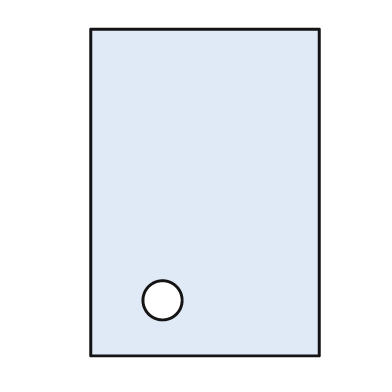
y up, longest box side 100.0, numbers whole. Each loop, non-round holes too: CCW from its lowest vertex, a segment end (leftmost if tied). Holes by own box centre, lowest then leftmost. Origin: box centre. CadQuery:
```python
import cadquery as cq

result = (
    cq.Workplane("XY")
    .moveTo(-35.0, -50.0)
    .lineTo(35.0, -50.0)
    .lineTo(35.0, 50.0)
    .lineTo(-35.0, 50.0)
    .close()
    .moveTo(-13.0, -33.0)
    .circle(6.0)
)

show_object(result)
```